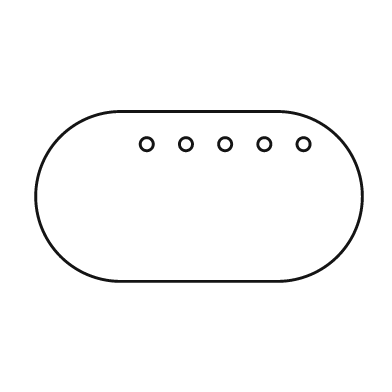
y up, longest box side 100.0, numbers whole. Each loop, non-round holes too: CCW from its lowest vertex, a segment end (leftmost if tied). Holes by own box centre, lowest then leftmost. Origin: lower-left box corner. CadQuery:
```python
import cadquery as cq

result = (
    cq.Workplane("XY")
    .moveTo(26.0, 0.0)
    .lineTo(74.0, 0.0)
    .threePointArc((100.0, 26.0), (74.0, 52.0))
    .lineTo(26.0, 52.0)
    .threePointArc((0.0, 26.0), (26.0, 0.0))
    .close()
    .moveTo(34.0, 42.0)
    .circle(2.0)
    .moveTo(46.0, 42.0)
    .circle(2.0)
    .moveTo(58.0, 42.0)
    .circle(2.0)
    .moveTo(70.0, 42.0)
    .circle(2.0)
    .moveTo(82.0, 42.0)
    .circle(2.0)
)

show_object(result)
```